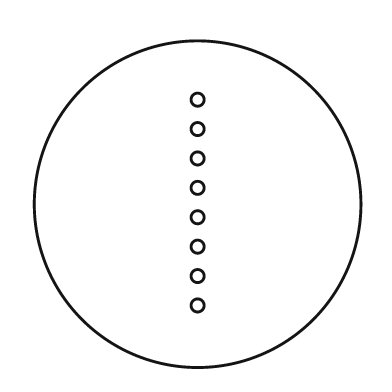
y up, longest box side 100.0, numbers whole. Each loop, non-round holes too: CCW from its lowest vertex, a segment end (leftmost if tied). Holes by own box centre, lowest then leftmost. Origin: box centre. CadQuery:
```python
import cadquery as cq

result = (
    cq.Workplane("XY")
    .moveTo(0.0, 0.0)
    .circle(50.0)
    .moveTo(0.0, -31.0)
    .circle(2.0)
    .moveTo(0.0, -22.0)
    .circle(2.0)
    .moveTo(0.0, -13.0)
    .circle(2.0)
    .moveTo(0.0, -4.0)
    .circle(2.0)
    .moveTo(0.0, 5.0)
    .circle(2.0)
    .moveTo(0.0, 14.0)
    .circle(2.0)
    .moveTo(0.0, 23.0)
    .circle(2.0)
    .moveTo(0.0, 32.0)
    .circle(2.0)
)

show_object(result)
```